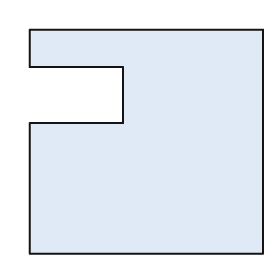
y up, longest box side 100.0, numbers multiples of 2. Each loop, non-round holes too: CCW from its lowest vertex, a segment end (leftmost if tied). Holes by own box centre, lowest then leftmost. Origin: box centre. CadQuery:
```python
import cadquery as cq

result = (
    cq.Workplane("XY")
    .moveTo(-50.0, -48.0)
    .lineTo(50.0, -48.0)
    .lineTo(50.0, 48.0)
    .lineTo(-50.0, 48.0)
    .lineTo(-50.0, 32.0)
    .lineTo(-10.0, 32.0)
    .lineTo(-10.0, 8.0)
    .lineTo(-50.0, 8.0)
    .close()
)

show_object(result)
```